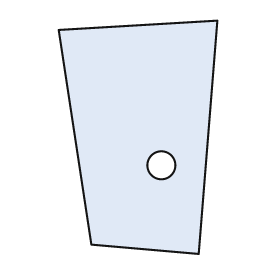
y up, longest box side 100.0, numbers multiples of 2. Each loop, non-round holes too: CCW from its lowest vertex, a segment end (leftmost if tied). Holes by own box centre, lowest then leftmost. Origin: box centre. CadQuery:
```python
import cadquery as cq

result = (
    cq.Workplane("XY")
    .moveTo(26.0, -50.0)
    .lineTo(34.0, 50.0)
    .lineTo(-34.0, 46.0)
    .lineTo(-20.0, -46.0)
    .close()
    .moveTo(10.0, -12.0)
    .circle(6.0)
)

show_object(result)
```